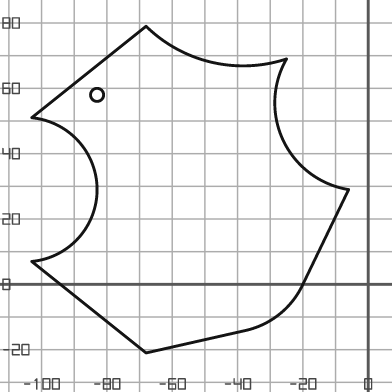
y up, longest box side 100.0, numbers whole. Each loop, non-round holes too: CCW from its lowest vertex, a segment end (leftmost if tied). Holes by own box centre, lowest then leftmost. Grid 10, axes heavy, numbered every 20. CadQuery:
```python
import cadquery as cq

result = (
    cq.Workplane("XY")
    .moveTo(-68.0, -21.0)
    .lineTo(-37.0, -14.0)
    .threePointArc((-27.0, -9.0), (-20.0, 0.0))
    .lineTo(-6.0, 29.0)
    .threePointArc((-26.0, 44.0), (-25.0, 69.0))
    .threePointArc((-48.0, 68.0), (-68.0, 79.0))
    .lineTo(-103.0, 51.0)
    .threePointArc((-83.0, 29.0), (-103.0, 7.0))
    .close()
    .moveTo(-83.0, 58.0)
    .circle(2.0)
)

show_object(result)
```